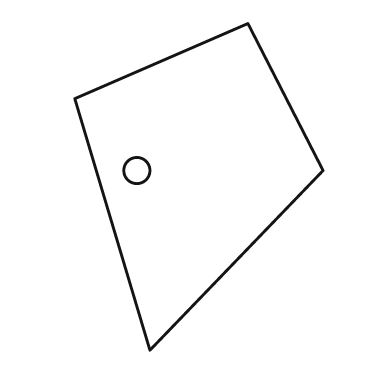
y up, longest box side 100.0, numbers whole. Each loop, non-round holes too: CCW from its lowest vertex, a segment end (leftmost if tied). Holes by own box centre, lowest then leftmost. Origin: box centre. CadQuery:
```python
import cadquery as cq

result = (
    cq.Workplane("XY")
    .moveTo(-15.0, -50.0)
    .lineTo(38.0, 5.0)
    .lineTo(15.0, 50.0)
    .lineTo(-38.0, 27.0)
    .close()
    .moveTo(-19.0, 5.0)
    .circle(4.0)
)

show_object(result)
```